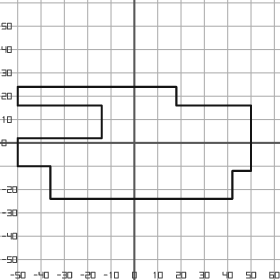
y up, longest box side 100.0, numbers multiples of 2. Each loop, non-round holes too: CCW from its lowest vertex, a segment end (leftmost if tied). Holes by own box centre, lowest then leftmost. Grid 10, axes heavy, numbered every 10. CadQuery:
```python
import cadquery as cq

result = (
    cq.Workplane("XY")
    .moveTo(-36.0, -24.0)
    .lineTo(42.0, -24.0)
    .lineTo(42.0, -12.0)
    .lineTo(50.0, -12.0)
    .lineTo(50.0, 16.0)
    .lineTo(18.0, 16.0)
    .lineTo(18.0, 24.0)
    .lineTo(-50.0, 24.0)
    .lineTo(-50.0, 16.0)
    .lineTo(-14.0, 16.0)
    .lineTo(-14.0, 2.0)
    .lineTo(-50.0, 2.0)
    .lineTo(-50.0, -10.0)
    .lineTo(-36.0, -10.0)
    .close()
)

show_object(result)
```